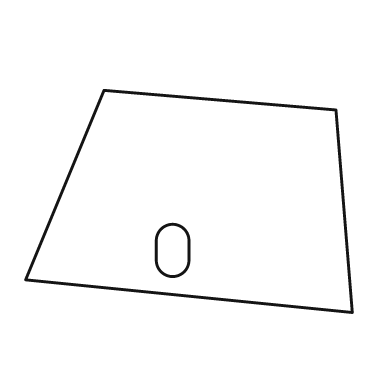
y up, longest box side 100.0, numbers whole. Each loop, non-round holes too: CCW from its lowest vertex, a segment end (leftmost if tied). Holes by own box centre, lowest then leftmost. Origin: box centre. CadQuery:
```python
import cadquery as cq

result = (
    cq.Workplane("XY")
    .moveTo(50.0, -34.0)
    .lineTo(45.0, 28.0)
    .lineTo(-26.0, 34.0)
    .lineTo(-50.0, -24.0)
    .close()
    .moveTo(-10.0, -18.0)
    .threePointArc((-5.0, -23.0), (0.0, -18.0))
    .lineTo(0.0, -12.0)
    .threePointArc((-5.0, -7.0), (-10.0, -12.0))
    .close()
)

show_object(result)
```